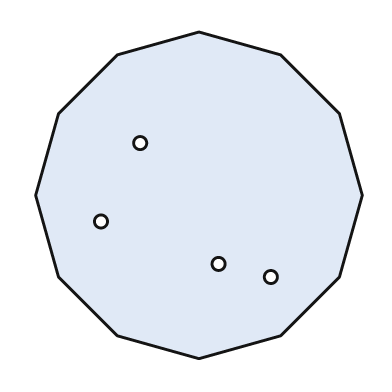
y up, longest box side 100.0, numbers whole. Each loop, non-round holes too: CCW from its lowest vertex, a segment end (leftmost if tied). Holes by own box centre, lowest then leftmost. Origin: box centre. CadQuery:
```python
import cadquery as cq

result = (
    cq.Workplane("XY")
    .moveTo(0.0, -50.0)
    .lineTo(25.0, -43.0)
    .lineTo(43.0, -25.0)
    .lineTo(50.0, 0.0)
    .lineTo(43.0, 25.0)
    .lineTo(25.0, 43.0)
    .lineTo(0.0, 50.0)
    .lineTo(-25.0, 43.0)
    .lineTo(-43.0, 25.0)
    .lineTo(-50.0, 0.0)
    .lineTo(-43.0, -25.0)
    .lineTo(-25.0, -43.0)
    .close()
    .moveTo(22.0, -25.0)
    .circle(2.0)
    .moveTo(6.0, -21.0)
    .circle(2.0)
    .moveTo(-30.0, -8.0)
    .circle(2.0)
    .moveTo(-18.0, 16.0)
    .circle(2.0)
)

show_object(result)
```